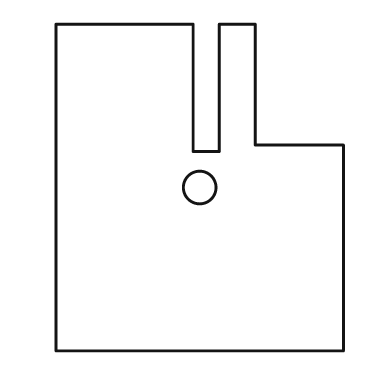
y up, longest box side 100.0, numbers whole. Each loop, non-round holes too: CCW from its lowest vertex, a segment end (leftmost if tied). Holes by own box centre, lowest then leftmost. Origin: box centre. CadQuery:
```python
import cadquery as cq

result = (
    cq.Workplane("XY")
    .moveTo(-44.0, -50.0)
    .lineTo(44.0, -50.0)
    .lineTo(44.0, 13.0)
    .lineTo(17.0, 13.0)
    .lineTo(17.0, 50.0)
    .lineTo(6.0, 50.0)
    .lineTo(6.0, 11.0)
    .lineTo(-2.0, 11.0)
    .lineTo(-2.0, 50.0)
    .lineTo(-44.0, 50.0)
    .close()
    .moveTo(0.0, 0.0)
    .circle(5.0)
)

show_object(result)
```